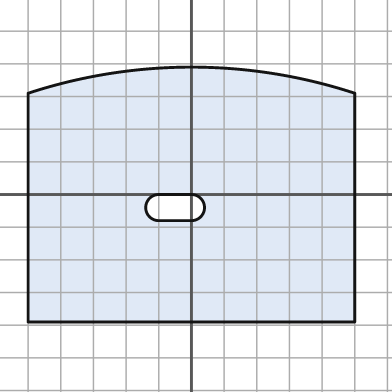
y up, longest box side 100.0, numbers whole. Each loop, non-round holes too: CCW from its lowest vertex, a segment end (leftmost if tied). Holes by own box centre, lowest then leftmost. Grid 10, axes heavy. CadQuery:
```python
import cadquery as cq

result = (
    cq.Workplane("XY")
    .moveTo(-50.0, -39.0)
    .lineTo(50.0, -39.0)
    .lineTo(50.0, 31.0)
    .threePointArc((0.0, 39.0), (-50.0, 31.0))
    .close()
    .moveTo(-10.0, -8.0)
    .lineTo(0.0, -8.0)
    .threePointArc((4.0, -4.0), (0.0, 0.0))
    .lineTo(-10.0, 0.0)
    .threePointArc((-14.0, -4.0), (-10.0, -8.0))
    .close()
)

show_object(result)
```